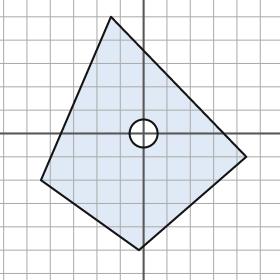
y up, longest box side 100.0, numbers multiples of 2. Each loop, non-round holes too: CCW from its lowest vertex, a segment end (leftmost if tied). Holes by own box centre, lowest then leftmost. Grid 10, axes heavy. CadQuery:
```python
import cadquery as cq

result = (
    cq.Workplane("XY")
    .moveTo(-2.0, -50.0)
    .lineTo(44.0, -10.0)
    .lineTo(-14.0, 50.0)
    .lineTo(-44.0, -20.0)
    .close()
    .moveTo(0.0, 0.0)
    .circle(6.0)
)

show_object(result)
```